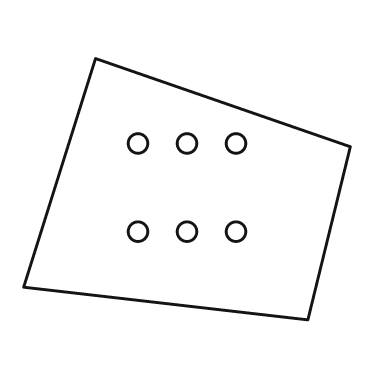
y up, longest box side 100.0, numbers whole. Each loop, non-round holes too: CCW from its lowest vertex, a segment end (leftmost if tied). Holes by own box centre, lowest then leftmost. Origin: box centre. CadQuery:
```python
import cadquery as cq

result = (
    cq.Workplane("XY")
    .moveTo(37.0, -40.0)
    .lineTo(50.0, 13.0)
    .lineTo(-28.0, 40.0)
    .lineTo(-50.0, -30.0)
    .close()
    .moveTo(-15.0, -13.0)
    .circle(3.0)
    .moveTo(0.0, -13.0)
    .circle(3.0)
    .moveTo(15.0, -13.0)
    .circle(3.0)
    .moveTo(-15.0, 14.0)
    .circle(3.0)
    .moveTo(0.0, 14.0)
    .circle(3.0)
    .moveTo(15.0, 14.0)
    .circle(3.0)
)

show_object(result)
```